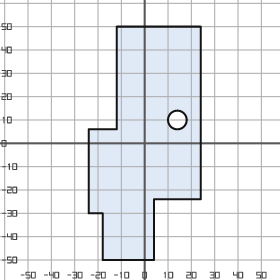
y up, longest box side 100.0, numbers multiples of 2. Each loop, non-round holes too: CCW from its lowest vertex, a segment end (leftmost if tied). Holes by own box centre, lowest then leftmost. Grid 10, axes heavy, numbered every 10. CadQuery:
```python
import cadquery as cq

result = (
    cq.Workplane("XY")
    .moveTo(-18.0, -50.0)
    .lineTo(4.0, -50.0)
    .lineTo(4.0, -24.0)
    .lineTo(24.0, -24.0)
    .lineTo(24.0, 50.0)
    .lineTo(-12.0, 50.0)
    .lineTo(-12.0, 6.0)
    .lineTo(-24.0, 6.0)
    .lineTo(-24.0, -30.0)
    .lineTo(-18.0, -30.0)
    .close()
    .moveTo(14.0, 10.0)
    .circle(4.0)
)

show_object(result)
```